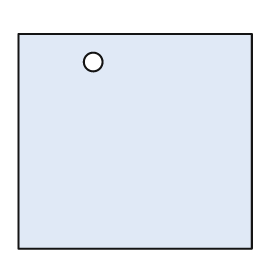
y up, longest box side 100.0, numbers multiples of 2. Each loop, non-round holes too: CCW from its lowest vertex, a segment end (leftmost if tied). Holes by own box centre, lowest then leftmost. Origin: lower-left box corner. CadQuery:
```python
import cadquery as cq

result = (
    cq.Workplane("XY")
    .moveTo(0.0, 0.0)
    .lineTo(100.0, 0.0)
    .lineTo(100.0, 92.0)
    .lineTo(0.0, 92.0)
    .close()
    .moveTo(32.0, 80.0)
    .circle(4.0)
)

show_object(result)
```